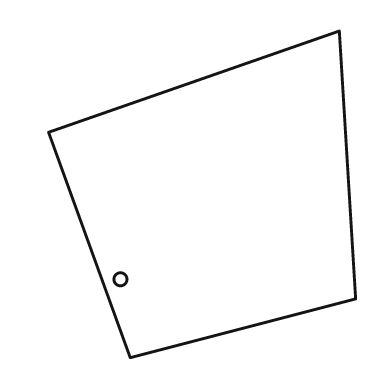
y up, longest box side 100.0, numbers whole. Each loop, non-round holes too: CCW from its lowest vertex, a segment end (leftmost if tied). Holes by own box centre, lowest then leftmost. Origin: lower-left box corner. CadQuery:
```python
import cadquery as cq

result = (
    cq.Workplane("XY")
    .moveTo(25.0, 0.0)
    .lineTo(94.0, 18.0)
    .lineTo(89.0, 100.0)
    .lineTo(0.0, 69.0)
    .close()
    .moveTo(22.0, 24.0)
    .circle(2.0)
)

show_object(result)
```